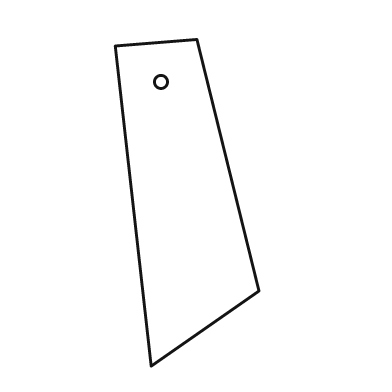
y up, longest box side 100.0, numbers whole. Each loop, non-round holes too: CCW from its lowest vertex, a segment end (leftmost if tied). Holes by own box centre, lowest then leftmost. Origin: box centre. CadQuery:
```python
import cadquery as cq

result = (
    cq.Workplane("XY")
    .moveTo(-11.0, -50.0)
    .lineTo(22.0, -27.0)
    .lineTo(3.0, 50.0)
    .lineTo(-22.0, 48.0)
    .close()
    .moveTo(-8.0, 37.0)
    .circle(2.0)
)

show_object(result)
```